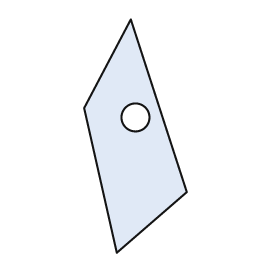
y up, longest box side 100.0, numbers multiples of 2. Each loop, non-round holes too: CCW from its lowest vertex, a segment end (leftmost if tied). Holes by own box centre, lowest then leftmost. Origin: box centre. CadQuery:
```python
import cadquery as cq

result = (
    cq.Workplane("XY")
    .moveTo(-8.0, -50.0)
    .lineTo(22.0, -24.0)
    .lineTo(-2.0, 50.0)
    .lineTo(-22.0, 12.0)
    .close()
    .moveTo(0.0, 8.0)
    .circle(6.0)
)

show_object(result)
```